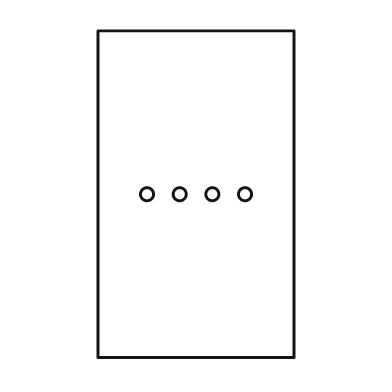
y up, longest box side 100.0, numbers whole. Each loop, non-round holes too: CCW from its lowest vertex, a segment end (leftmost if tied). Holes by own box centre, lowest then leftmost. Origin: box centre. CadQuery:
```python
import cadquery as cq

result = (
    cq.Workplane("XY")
    .moveTo(-30.0, -50.0)
    .lineTo(30.0, -50.0)
    .lineTo(30.0, 50.0)
    .lineTo(-30.0, 50.0)
    .close()
    .moveTo(-15.0, 0.0)
    .circle(2.0)
    .moveTo(-5.0, 0.0)
    .circle(2.0)
    .moveTo(5.0, 0.0)
    .circle(2.0)
    .moveTo(15.0, 0.0)
    .circle(2.0)
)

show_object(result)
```